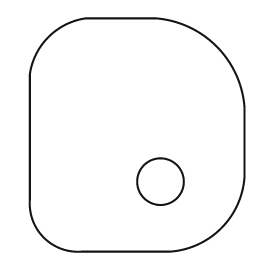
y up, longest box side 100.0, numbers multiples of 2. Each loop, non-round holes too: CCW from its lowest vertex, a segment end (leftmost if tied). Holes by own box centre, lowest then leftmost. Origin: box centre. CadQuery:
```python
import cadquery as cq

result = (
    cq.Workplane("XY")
    .moveTo(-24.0, -50.0)
    .lineTo(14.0, -50.0)
    .threePointArc((36.0, -40.0), (46.0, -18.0))
    .lineTo(46.0, 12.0)
    .threePointArc((34.0, 38.0), (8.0, 50.0))
    .lineTo(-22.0, 50.0)
    .threePointArc((-38.0, 42.0), (-46.0, 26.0))
    .lineTo(-46.0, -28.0)
    .threePointArc((-40.0, -44.0), (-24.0, -50.0))
    .close()
    .moveTo(10.0, -20.0)
    .circle(10.0)
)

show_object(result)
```